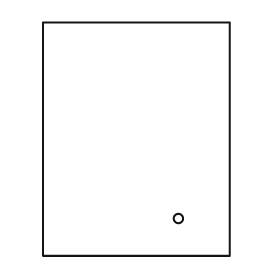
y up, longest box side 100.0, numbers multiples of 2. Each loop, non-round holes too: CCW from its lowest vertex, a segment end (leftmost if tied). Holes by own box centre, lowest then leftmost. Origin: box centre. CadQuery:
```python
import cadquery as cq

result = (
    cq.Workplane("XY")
    .moveTo(-40.0, -50.0)
    .lineTo(40.0, -50.0)
    .lineTo(40.0, 50.0)
    .lineTo(-40.0, 50.0)
    .close()
    .moveTo(18.0, -34.0)
    .circle(2.0)
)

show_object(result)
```